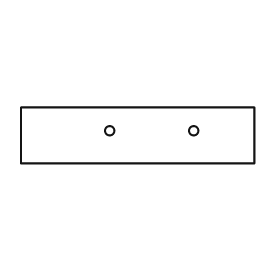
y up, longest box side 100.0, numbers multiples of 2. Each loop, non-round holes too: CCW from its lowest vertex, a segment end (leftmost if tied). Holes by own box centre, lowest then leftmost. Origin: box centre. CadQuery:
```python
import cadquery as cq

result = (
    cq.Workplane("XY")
    .moveTo(-50.0, -12.0)
    .lineTo(50.0, -12.0)
    .lineTo(50.0, 12.0)
    .lineTo(-50.0, 12.0)
    .close()
    .moveTo(-12.0, 2.0)
    .circle(2.0)
    .moveTo(24.0, 2.0)
    .circle(2.0)
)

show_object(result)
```